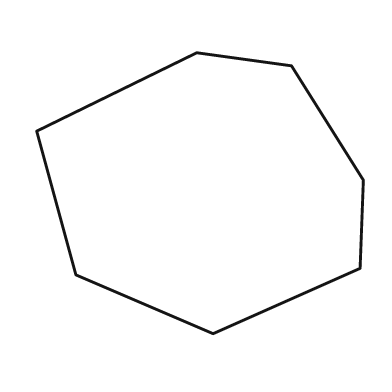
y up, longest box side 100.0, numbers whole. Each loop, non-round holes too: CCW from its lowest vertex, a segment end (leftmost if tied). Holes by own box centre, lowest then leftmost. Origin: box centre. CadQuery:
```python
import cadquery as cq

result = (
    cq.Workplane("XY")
    .moveTo(4.0, -43.0)
    .lineTo(49.0, -23.0)
    .lineTo(50.0, 4.0)
    .lineTo(28.0, 39.0)
    .lineTo(-1.0, 43.0)
    .lineTo(-50.0, 19.0)
    .lineTo(-38.0, -25.0)
    .close()
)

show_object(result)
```